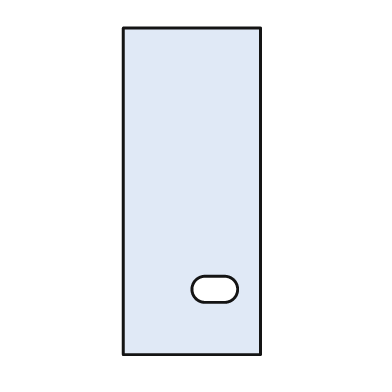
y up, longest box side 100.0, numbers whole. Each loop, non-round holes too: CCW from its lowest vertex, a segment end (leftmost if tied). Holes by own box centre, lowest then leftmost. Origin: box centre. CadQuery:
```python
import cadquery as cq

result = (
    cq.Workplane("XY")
    .moveTo(-21.0, -50.0)
    .lineTo(21.0, -50.0)
    .lineTo(21.0, 50.0)
    .lineTo(-21.0, 50.0)
    .close()
    .moveTo(4.0, -34.0)
    .lineTo(10.0, -34.0)
    .threePointArc((14.0, -30.0), (10.0, -26.0))
    .lineTo(4.0, -26.0)
    .threePointArc((0.0, -30.0), (4.0, -34.0))
    .close()
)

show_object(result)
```